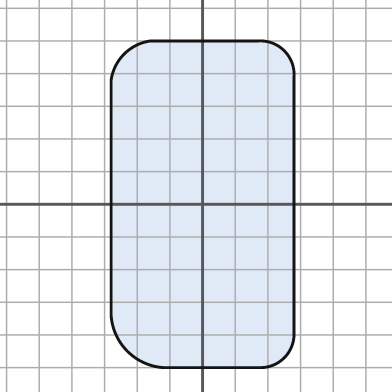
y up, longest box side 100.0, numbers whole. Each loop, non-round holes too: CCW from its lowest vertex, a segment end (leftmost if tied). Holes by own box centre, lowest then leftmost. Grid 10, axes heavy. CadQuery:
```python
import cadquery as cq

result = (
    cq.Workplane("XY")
    .moveTo(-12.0, -50.0)
    .lineTo(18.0, -50.0)
    .threePointArc((25.0, -47.0), (28.0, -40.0))
    .lineTo(28.0, 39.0)
    .threePointArc((25.0, 47.0), (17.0, 50.0))
    .lineTo(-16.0, 50.0)
    .threePointArc((-24.0, 46.0), (-28.0, 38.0))
    .lineTo(-28.0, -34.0)
    .threePointArc((-23.0, -45.0), (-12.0, -50.0))
    .close()
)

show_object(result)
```